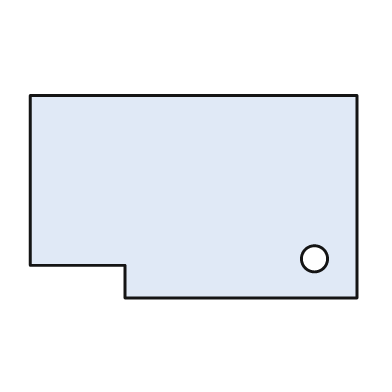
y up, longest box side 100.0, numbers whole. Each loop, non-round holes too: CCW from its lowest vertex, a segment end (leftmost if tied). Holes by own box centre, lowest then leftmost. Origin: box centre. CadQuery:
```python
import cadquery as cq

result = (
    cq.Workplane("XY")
    .moveTo(-21.0, -31.0)
    .lineTo(50.0, -31.0)
    .lineTo(50.0, 31.0)
    .lineTo(-50.0, 31.0)
    .lineTo(-50.0, -21.0)
    .lineTo(-21.0, -21.0)
    .close()
    .moveTo(37.0, -19.0)
    .circle(4.0)
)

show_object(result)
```